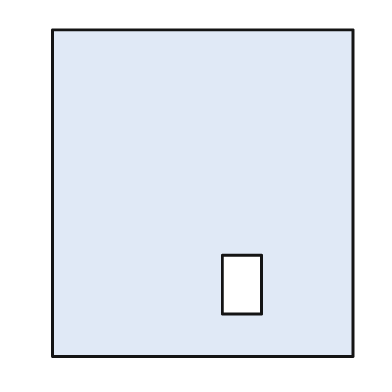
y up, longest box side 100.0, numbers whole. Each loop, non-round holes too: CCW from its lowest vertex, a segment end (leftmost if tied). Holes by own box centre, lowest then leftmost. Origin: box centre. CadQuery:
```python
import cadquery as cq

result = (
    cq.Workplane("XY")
    .moveTo(-46.0, -50.0)
    .lineTo(46.0, -50.0)
    .lineTo(46.0, 50.0)
    .lineTo(-46.0, 50.0)
    .close()
    .moveTo(6.0, -37.0)
    .lineTo(18.0, -37.0)
    .lineTo(18.0, -19.0)
    .lineTo(6.0, -19.0)
    .close()
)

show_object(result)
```